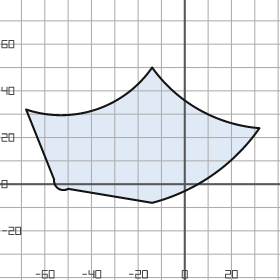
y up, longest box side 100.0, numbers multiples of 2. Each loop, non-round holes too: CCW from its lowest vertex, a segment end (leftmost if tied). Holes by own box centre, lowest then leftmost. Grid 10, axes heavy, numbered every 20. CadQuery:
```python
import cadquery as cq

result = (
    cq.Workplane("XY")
    .moveTo(-14.0, -8.0)
    .threePointArc((12.0, 4.0), (32.0, 24.0))
    .threePointArc((6.0, 32.0), (-14.0, 50.0))
    .threePointArc((-38.0, 32.0), (-68.0, 32.0))
    .lineTo(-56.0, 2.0)
    .threePointArc((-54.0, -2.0), (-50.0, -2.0))
    .close()
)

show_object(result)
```